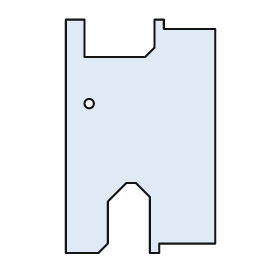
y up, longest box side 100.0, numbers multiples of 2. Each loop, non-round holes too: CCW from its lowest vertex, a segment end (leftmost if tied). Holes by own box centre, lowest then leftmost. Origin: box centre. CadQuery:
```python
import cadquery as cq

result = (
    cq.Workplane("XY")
    .moveTo(-32.0, -50.0)
    .lineTo(-18.0, -50.0)
    .lineTo(-14.0, -46.0)
    .lineTo(-14.0, -28.0)
    .lineTo(-6.0, -20.0)
    .lineTo(-2.0, -20.0)
    .lineTo(4.0, -26.0)
    .lineTo(4.0, -50.0)
    .lineTo(8.0, -50.0)
    .lineTo(8.0, -46.0)
    .lineTo(32.0, -46.0)
    .lineTo(32.0, 46.0)
    .lineTo(10.0, 46.0)
    .lineTo(10.0, 50.0)
    .lineTo(6.0, 50.0)
    .lineTo(6.0, 38.0)
    .lineTo(2.0, 34.0)
    .lineTo(-24.0, 34.0)
    .lineTo(-24.0, 50.0)
    .lineTo(-32.0, 50.0)
    .close()
    .moveTo(-22.0, 14.0)
    .circle(2.0)
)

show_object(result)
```